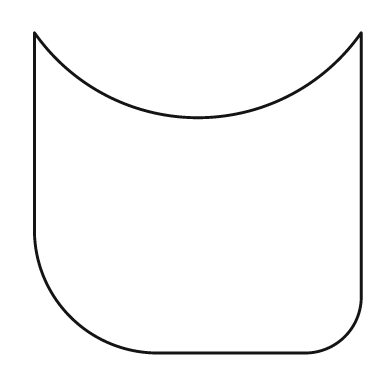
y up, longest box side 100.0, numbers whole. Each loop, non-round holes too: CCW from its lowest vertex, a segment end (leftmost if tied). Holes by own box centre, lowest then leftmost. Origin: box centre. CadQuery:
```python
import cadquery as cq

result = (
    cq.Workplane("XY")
    .moveTo(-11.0, -49.0)
    .lineTo(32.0, -49.0)
    .threePointArc((45.0, -44.0), (50.0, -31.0))
    .lineTo(50.0, 49.0)
    .threePointArc((0.0, 23.0), (-50.0, 49.0))
    .lineTo(-50.0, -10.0)
    .threePointArc((-39.0, -38.0), (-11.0, -49.0))
    .close()
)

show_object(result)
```